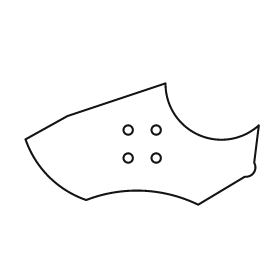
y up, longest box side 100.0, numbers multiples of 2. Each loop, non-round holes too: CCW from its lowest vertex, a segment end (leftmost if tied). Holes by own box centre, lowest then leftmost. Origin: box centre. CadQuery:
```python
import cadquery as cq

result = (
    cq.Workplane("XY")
    .moveTo(24.0, -26.0)
    .lineTo(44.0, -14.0)
    .threePointArc((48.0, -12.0), (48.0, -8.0))
    .lineTo(50.0, 8.0)
    .threePointArc((24.0, 4.0), (10.0, 26.0))
    .lineTo(-32.0, 12.0)
    .lineTo(-50.0, 2.0)
    .threePointArc((-40.0, -14.0), (-24.0, -24.0))
    .threePointArc((0.0, -20.0), (24.0, -26.0))
    .close()
    .moveTo(-6.0, -6.0)
    .circle(2.0)
    .moveTo(6.0, -6.0)
    .circle(2.0)
    .moveTo(-6.0, 6.0)
    .circle(2.0)
    .moveTo(6.0, 6.0)
    .circle(2.0)
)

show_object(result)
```